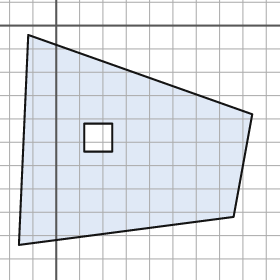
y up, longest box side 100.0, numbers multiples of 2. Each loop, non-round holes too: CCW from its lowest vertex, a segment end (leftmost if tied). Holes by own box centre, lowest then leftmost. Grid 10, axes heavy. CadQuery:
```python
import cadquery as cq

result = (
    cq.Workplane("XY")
    .moveTo(-16.0, -94.0)
    .lineTo(76.0, -82.0)
    .lineTo(84.0, -38.0)
    .lineTo(-12.0, -4.0)
    .close()
    .moveTo(12.0, -54.0)
    .lineTo(24.0, -54.0)
    .lineTo(24.0, -42.0)
    .lineTo(12.0, -42.0)
    .close()
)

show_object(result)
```